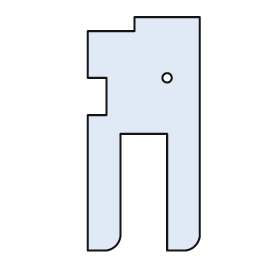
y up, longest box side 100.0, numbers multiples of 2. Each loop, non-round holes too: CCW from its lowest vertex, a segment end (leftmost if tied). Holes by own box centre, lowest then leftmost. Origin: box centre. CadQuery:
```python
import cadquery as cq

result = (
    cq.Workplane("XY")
    .moveTo(-24.0, -50.0)
    .lineTo(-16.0, -50.0)
    .threePointArc((-12.0, -48.0), (-10.0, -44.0))
    .lineTo(-10.0, 0.0)
    .lineTo(10.0, 0.0)
    .lineTo(10.0, -50.0)
    .lineTo(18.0, -50.0)
    .threePointArc((22.0, -48.0), (24.0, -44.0))
    .lineTo(24.0, 50.0)
    .lineTo(-4.0, 50.0)
    .lineTo(-4.0, 44.0)
    .lineTo(-24.0, 44.0)
    .lineTo(-24.0, 24.0)
    .lineTo(-16.0, 24.0)
    .lineTo(-16.0, 8.0)
    .lineTo(-24.0, 8.0)
    .close()
    .moveTo(10.0, 24.0)
    .circle(2.0)
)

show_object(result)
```